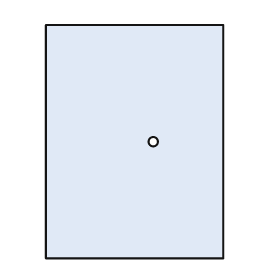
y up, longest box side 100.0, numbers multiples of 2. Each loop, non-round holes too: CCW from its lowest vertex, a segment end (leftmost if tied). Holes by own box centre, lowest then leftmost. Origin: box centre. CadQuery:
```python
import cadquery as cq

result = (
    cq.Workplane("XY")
    .moveTo(-38.0, -50.0)
    .lineTo(38.0, -50.0)
    .lineTo(38.0, 50.0)
    .lineTo(-38.0, 50.0)
    .close()
    .moveTo(8.0, 0.0)
    .circle(2.0)
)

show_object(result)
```